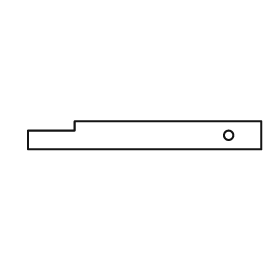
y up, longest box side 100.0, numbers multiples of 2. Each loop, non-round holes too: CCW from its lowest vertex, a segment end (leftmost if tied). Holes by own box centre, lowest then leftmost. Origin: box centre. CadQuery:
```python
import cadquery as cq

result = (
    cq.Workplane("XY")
    .moveTo(-50.0, -6.0)
    .lineTo(50.0, -6.0)
    .lineTo(50.0, 6.0)
    .lineTo(-30.0, 6.0)
    .lineTo(-30.0, 2.0)
    .lineTo(-50.0, 2.0)
    .close()
    .moveTo(36.0, 0.0)
    .circle(2.0)
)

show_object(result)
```